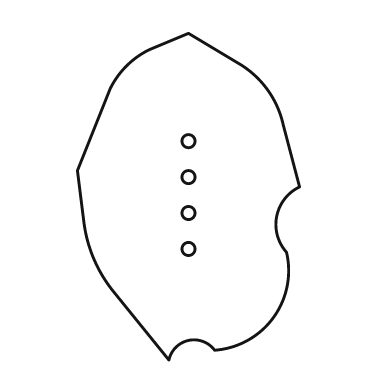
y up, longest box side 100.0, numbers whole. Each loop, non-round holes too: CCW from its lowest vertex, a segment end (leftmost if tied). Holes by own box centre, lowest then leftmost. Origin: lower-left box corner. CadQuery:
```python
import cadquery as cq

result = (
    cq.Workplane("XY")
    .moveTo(28.0, 0.0)
    .threePointArc((34.0, 6.0), (42.0, 3.0))
    .threePointArc((60.0, 13.0), (64.0, 33.0))
    .threePointArc((61.0, 44.0), (68.0, 53.0))
    .lineTo(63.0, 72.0)
    .threePointArc((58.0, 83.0), (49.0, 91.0))
    .lineTo(34.0, 100.0)
    .lineTo(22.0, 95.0)
    .threePointArc((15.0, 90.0), (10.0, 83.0))
    .lineTo(0.0, 58.0)
    .lineTo(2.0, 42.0)
    .threePointArc((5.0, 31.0), (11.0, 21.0))
    .close()
    .moveTo(34.0, 34.0)
    .circle(2.0)
    .moveTo(34.0, 45.0)
    .circle(2.0)
    .moveTo(34.0, 56.0)
    .circle(2.0)
    .moveTo(34.0, 67.0)
    .circle(2.0)
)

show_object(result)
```